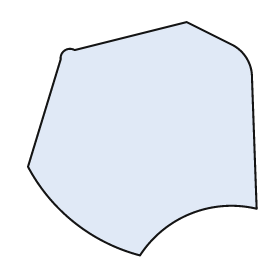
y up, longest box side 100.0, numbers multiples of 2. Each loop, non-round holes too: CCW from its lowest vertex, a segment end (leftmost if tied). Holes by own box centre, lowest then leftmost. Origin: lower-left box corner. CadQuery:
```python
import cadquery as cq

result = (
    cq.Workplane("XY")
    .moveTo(48.0, 0.0)
    .threePointArc((70.0, 18.0), (98.0, 20.0))
    .lineTo(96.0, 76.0)
    .threePointArc((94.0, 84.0), (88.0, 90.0))
    .lineTo(68.0, 100.0)
    .lineTo(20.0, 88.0)
    .threePointArc((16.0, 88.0), (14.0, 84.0))
    .lineTo(0.0, 38.0)
    .threePointArc((20.0, 14.0), (48.0, 0.0))
    .close()
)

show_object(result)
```